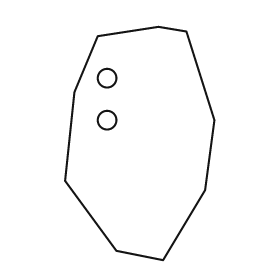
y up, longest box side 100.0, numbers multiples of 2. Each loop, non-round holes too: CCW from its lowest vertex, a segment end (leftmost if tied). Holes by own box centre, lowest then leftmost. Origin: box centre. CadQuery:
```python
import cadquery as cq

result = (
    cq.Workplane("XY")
    .moveTo(10.0, -50.0)
    .lineTo(28.0, -20.0)
    .lineTo(32.0, 10.0)
    .lineTo(20.0, 48.0)
    .lineTo(8.0, 50.0)
    .lineTo(-18.0, 46.0)
    .lineTo(-28.0, 22.0)
    .lineTo(-32.0, -16.0)
    .lineTo(-10.0, -46.0)
    .close()
    .moveTo(-14.0, 10.0)
    .circle(4.0)
    .moveTo(-14.0, 28.0)
    .circle(4.0)
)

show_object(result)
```